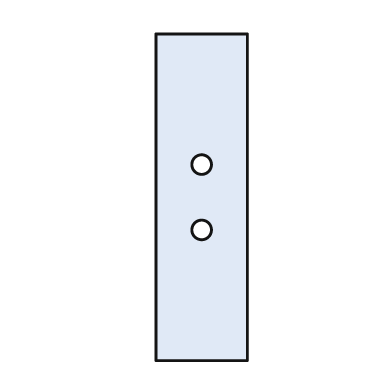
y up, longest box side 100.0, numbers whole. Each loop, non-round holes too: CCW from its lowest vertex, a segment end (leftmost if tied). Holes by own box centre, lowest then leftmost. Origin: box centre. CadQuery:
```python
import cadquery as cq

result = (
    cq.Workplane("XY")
    .moveTo(-14.0, -50.0)
    .lineTo(14.0, -50.0)
    .lineTo(14.0, 50.0)
    .lineTo(-14.0, 50.0)
    .close()
    .moveTo(0.0, -10.0)
    .circle(3.0)
    .moveTo(0.0, 10.0)
    .circle(3.0)
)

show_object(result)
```